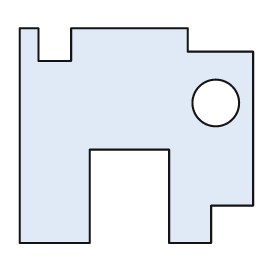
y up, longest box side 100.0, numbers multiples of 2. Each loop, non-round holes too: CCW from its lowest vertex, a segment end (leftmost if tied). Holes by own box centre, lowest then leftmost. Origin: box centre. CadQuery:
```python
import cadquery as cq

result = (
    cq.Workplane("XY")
    .moveTo(-50.0, -46.0)
    .lineTo(-20.0, -46.0)
    .lineTo(-20.0, -6.0)
    .lineTo(14.0, -6.0)
    .lineTo(14.0, -46.0)
    .lineTo(32.0, -46.0)
    .lineTo(32.0, -30.0)
    .lineTo(50.0, -30.0)
    .lineTo(50.0, 36.0)
    .lineTo(22.0, 36.0)
    .lineTo(22.0, 46.0)
    .lineTo(-28.0, 46.0)
    .lineTo(-28.0, 32.0)
    .lineTo(-42.0, 32.0)
    .lineTo(-42.0, 46.0)
    .lineTo(-50.0, 46.0)
    .close()
    .moveTo(34.0, 14.0)
    .circle(10.0)
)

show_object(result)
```